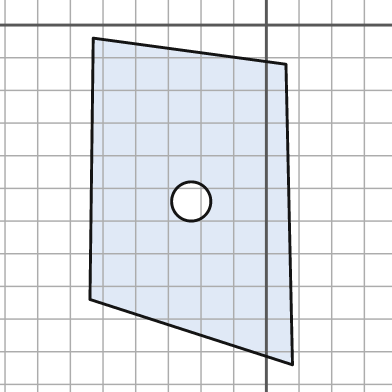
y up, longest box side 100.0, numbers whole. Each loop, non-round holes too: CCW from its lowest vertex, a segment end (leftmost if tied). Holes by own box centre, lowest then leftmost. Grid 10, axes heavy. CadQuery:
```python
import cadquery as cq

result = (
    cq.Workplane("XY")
    .moveTo(8.0, -104.0)
    .lineTo(6.0, -12.0)
    .lineTo(-53.0, -4.0)
    .lineTo(-54.0, -84.0)
    .close()
    .moveTo(-23.0, -54.0)
    .circle(6.0)
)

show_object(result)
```